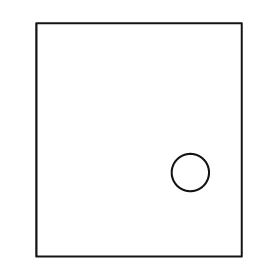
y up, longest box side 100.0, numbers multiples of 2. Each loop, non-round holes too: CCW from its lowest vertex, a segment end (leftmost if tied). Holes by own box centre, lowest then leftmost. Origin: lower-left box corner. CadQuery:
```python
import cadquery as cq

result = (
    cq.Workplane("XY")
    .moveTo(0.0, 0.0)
    .lineTo(88.0, 0.0)
    .lineTo(88.0, 100.0)
    .lineTo(0.0, 100.0)
    .close()
    .moveTo(66.0, 36.0)
    .circle(8.0)
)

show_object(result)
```